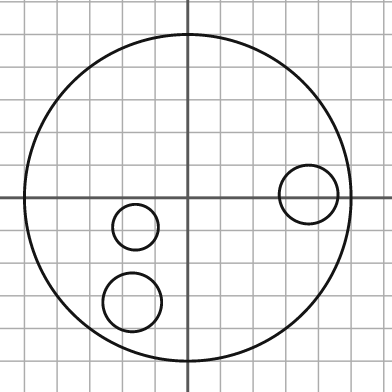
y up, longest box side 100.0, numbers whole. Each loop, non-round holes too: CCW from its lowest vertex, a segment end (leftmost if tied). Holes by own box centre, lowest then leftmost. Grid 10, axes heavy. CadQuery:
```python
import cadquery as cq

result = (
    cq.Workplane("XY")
    .moveTo(0.0, 0.0)
    .circle(50.0)
    .moveTo(-17.0, -32.0)
    .circle(9.0)
    .moveTo(-16.0, -9.0)
    .circle(7.0)
    .moveTo(37.0, 1.0)
    .circle(9.0)
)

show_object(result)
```